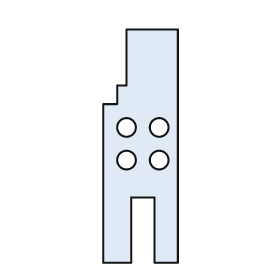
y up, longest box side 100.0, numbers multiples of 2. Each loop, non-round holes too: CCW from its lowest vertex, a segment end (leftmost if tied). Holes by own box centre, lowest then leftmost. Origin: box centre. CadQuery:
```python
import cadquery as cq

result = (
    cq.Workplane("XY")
    .moveTo(-16.0, -50.0)
    .lineTo(-4.0, -50.0)
    .lineTo(-4.0, -22.0)
    .lineTo(6.0, -22.0)
    .lineTo(6.0, -50.0)
    .lineTo(16.0, -50.0)
    .lineTo(16.0, 50.0)
    .lineTo(-6.0, 50.0)
    .lineTo(-6.0, 26.0)
    .lineTo(-10.0, 26.0)
    .lineTo(-10.0, 18.0)
    .lineTo(-16.0, 18.0)
    .close()
    .moveTo(-6.0, -6.0)
    .circle(4.0)
    .moveTo(8.0, -6.0)
    .circle(4.0)
    .moveTo(-6.0, 8.0)
    .circle(4.0)
    .moveTo(8.0, 8.0)
    .circle(4.0)
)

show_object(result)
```